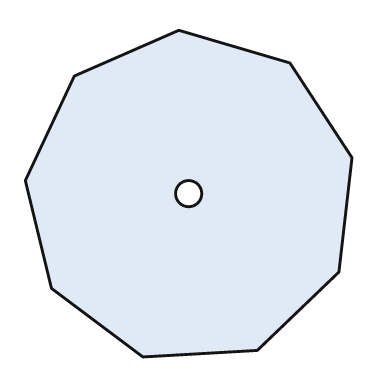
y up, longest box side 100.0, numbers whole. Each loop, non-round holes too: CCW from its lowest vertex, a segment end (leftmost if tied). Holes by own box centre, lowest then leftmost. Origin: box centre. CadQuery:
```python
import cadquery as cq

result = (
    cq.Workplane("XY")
    .moveTo(-14.0, -50.0)
    .lineTo(21.0, -48.0)
    .lineTo(46.0, -24.0)
    .lineTo(50.0, 11.0)
    .lineTo(31.0, 40.0)
    .lineTo(-3.0, 50.0)
    .lineTo(-35.0, 36.0)
    .lineTo(-50.0, 4.0)
    .lineTo(-42.0, -29.0)
    .close()
    .moveTo(0.0, 0.0)
    .circle(4.0)
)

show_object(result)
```